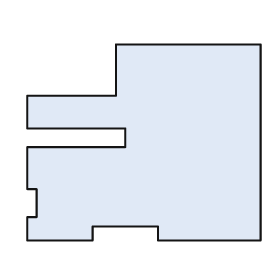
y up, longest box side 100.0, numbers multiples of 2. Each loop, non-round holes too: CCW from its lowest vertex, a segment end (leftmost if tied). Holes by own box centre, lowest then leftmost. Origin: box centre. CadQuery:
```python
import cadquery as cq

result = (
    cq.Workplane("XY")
    .moveTo(-50.0, -42.0)
    .lineTo(-22.0, -42.0)
    .lineTo(-22.0, -36.0)
    .lineTo(6.0, -36.0)
    .lineTo(6.0, -42.0)
    .lineTo(50.0, -42.0)
    .lineTo(50.0, 42.0)
    .lineTo(-12.0, 42.0)
    .lineTo(-12.0, 20.0)
    .lineTo(-50.0, 20.0)
    .lineTo(-50.0, 6.0)
    .lineTo(-8.0, 6.0)
    .lineTo(-8.0, -2.0)
    .lineTo(-50.0, -2.0)
    .lineTo(-50.0, -20.0)
    .lineTo(-46.0, -20.0)
    .lineTo(-46.0, -32.0)
    .lineTo(-50.0, -32.0)
    .close()
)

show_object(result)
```